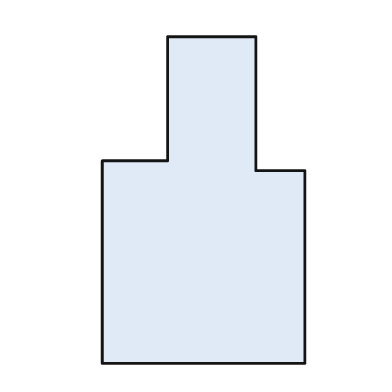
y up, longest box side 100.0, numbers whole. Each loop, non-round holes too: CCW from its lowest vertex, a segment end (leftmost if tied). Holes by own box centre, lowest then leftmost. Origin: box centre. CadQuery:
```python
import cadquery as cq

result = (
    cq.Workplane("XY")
    .moveTo(-31.0, -50.0)
    .lineTo(31.0, -50.0)
    .lineTo(31.0, 9.0)
    .lineTo(16.0, 9.0)
    .lineTo(16.0, 50.0)
    .lineTo(-11.0, 50.0)
    .lineTo(-11.0, 12.0)
    .lineTo(-31.0, 12.0)
    .close()
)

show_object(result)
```